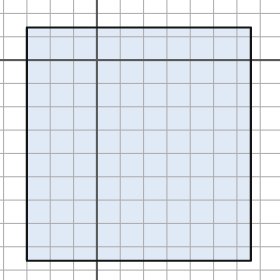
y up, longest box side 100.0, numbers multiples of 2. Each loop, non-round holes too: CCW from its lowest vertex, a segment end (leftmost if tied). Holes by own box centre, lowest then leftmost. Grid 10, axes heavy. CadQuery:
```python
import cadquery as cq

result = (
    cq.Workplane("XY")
    .moveTo(-30.0, -86.0)
    .lineTo(66.0, -86.0)
    .lineTo(66.0, 14.0)
    .lineTo(-30.0, 14.0)
    .close()
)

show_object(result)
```